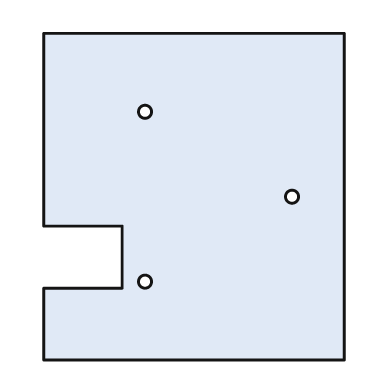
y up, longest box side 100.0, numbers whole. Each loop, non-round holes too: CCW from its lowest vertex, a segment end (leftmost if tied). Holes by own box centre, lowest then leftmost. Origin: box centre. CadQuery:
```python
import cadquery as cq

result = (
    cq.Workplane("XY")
    .moveTo(-46.0, -50.0)
    .lineTo(46.0, -50.0)
    .lineTo(46.0, 50.0)
    .lineTo(-46.0, 50.0)
    .lineTo(-46.0, -9.0)
    .lineTo(-22.0, -9.0)
    .lineTo(-22.0, -28.0)
    .lineTo(-46.0, -28.0)
    .close()
    .moveTo(-15.0, -26.0)
    .circle(2.0)
    .moveTo(30.0, 0.0)
    .circle(2.0)
    .moveTo(-15.0, 26.0)
    .circle(2.0)
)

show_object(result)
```